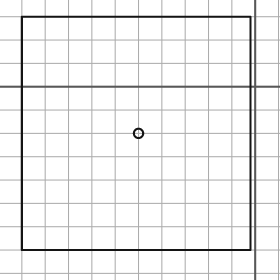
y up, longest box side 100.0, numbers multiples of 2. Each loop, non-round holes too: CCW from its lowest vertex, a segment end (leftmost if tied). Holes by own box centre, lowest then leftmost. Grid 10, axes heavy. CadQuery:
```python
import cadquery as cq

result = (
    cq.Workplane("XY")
    .moveTo(-100.0, -70.0)
    .lineTo(-2.0, -70.0)
    .lineTo(-2.0, 30.0)
    .lineTo(-100.0, 30.0)
    .close()
    .moveTo(-50.0, -20.0)
    .circle(2.0)
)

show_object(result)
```